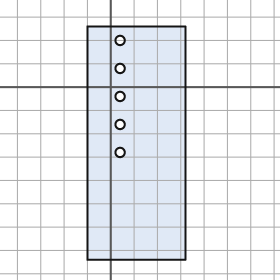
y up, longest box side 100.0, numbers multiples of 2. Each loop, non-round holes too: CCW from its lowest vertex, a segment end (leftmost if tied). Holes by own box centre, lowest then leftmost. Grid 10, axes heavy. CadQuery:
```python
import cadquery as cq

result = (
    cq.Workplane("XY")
    .moveTo(-10.0, -74.0)
    .lineTo(32.0, -74.0)
    .lineTo(32.0, 26.0)
    .lineTo(-10.0, 26.0)
    .close()
    .moveTo(4.0, -28.0)
    .circle(2.0)
    .moveTo(4.0, -16.0)
    .circle(2.0)
    .moveTo(4.0, -4.0)
    .circle(2.0)
    .moveTo(4.0, 8.0)
    .circle(2.0)
    .moveTo(4.0, 20.0)
    .circle(2.0)
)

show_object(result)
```